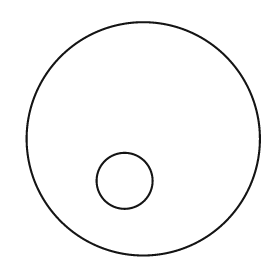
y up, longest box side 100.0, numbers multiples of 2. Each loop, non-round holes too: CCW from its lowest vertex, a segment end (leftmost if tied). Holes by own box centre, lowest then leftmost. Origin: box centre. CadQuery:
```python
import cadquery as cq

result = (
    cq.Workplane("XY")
    .moveTo(0.0, 0.0)
    .circle(50.0)
    .moveTo(-8.0, -18.0)
    .circle(12.0)
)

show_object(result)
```